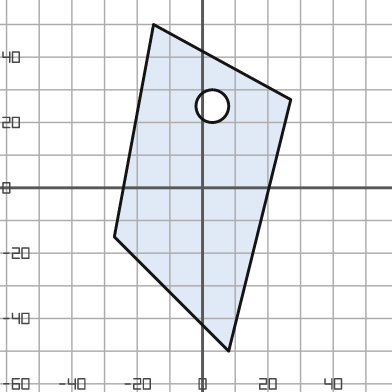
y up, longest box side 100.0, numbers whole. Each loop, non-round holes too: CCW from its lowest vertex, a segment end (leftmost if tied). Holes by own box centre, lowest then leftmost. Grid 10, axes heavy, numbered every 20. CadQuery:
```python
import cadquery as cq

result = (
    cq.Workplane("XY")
    .moveTo(8.0, -50.0)
    .lineTo(27.0, 27.0)
    .lineTo(-15.0, 50.0)
    .lineTo(-27.0, -15.0)
    .close()
    .moveTo(3.0, 25.0)
    .circle(5.0)
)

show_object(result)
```